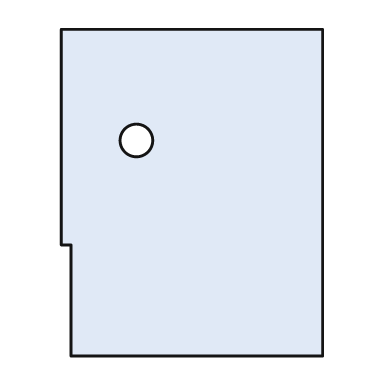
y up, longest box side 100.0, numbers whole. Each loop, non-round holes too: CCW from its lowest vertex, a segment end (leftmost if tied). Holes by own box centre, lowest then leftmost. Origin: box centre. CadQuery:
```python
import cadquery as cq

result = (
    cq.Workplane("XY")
    .moveTo(-37.0, -50.0)
    .lineTo(40.0, -50.0)
    .lineTo(40.0, 50.0)
    .lineTo(-40.0, 50.0)
    .lineTo(-40.0, -16.0)
    .lineTo(-37.0, -16.0)
    .close()
    .moveTo(-17.0, 16.0)
    .circle(5.0)
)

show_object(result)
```